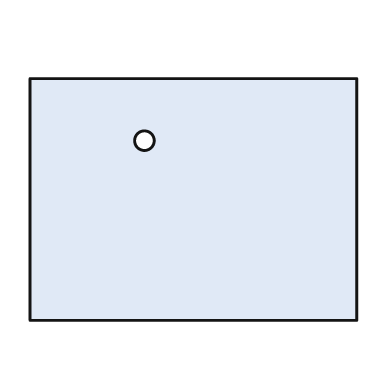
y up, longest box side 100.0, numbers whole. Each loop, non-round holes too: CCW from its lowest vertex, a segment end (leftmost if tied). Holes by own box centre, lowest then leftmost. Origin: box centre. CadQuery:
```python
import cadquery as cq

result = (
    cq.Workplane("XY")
    .moveTo(-50.0, -37.0)
    .lineTo(50.0, -37.0)
    .lineTo(50.0, 37.0)
    .lineTo(-50.0, 37.0)
    .close()
    .moveTo(-15.0, 18.0)
    .circle(3.0)
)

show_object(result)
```